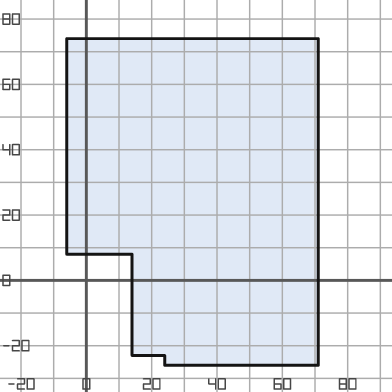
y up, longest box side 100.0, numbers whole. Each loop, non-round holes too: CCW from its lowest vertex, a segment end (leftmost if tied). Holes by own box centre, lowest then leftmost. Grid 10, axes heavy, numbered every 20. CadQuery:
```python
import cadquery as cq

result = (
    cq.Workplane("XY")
    .moveTo(24.0, -26.0)
    .lineTo(71.0, -26.0)
    .lineTo(71.0, 74.0)
    .lineTo(-6.0, 74.0)
    .lineTo(-6.0, 8.0)
    .lineTo(14.0, 8.0)
    .lineTo(14.0, -23.0)
    .lineTo(24.0, -23.0)
    .close()
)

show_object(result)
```